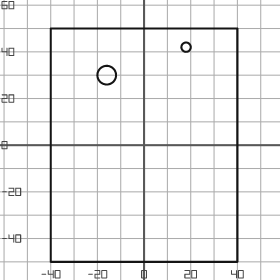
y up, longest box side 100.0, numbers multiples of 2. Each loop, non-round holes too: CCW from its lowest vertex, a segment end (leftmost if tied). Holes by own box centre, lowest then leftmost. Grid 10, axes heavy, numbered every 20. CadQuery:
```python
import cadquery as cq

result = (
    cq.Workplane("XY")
    .moveTo(-40.0, -50.0)
    .lineTo(40.0, -50.0)
    .lineTo(40.0, 50.0)
    .lineTo(-40.0, 50.0)
    .close()
    .moveTo(-16.0, 30.0)
    .circle(4.0)
    .moveTo(18.0, 42.0)
    .circle(2.0)
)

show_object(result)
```